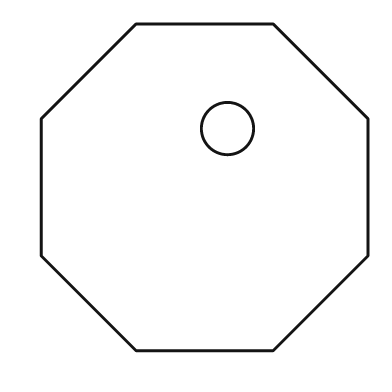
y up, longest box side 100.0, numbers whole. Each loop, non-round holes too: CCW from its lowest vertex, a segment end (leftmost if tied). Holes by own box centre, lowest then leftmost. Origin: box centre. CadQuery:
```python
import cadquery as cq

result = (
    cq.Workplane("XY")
    .moveTo(-21.0, -50.0)
    .lineTo(21.0, -50.0)
    .lineTo(50.0, -21.0)
    .lineTo(50.0, 21.0)
    .lineTo(21.0, 50.0)
    .lineTo(-21.0, 50.0)
    .lineTo(-50.0, 21.0)
    .lineTo(-50.0, -21.0)
    .close()
    .moveTo(7.0, 18.0)
    .circle(8.0)
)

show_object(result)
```